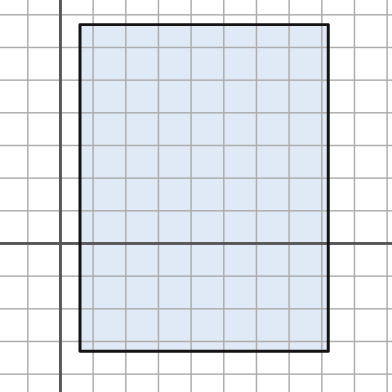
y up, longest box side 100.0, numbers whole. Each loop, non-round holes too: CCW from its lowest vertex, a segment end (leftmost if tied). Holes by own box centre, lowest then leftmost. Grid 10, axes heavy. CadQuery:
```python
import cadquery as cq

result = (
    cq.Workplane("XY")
    .moveTo(6.0, -33.0)
    .lineTo(82.0, -33.0)
    .lineTo(82.0, 67.0)
    .lineTo(6.0, 67.0)
    .close()
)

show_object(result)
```